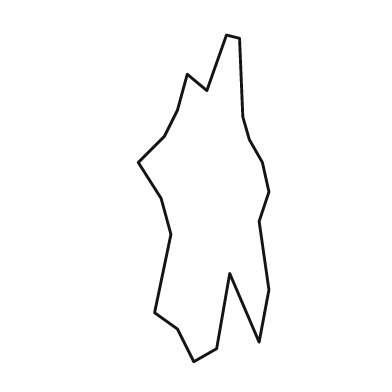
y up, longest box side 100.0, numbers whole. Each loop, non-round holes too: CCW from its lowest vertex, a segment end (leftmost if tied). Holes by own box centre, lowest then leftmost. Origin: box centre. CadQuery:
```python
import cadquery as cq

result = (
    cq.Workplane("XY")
    .moveTo(-3.0, -50.0)
    .lineTo(4.0, -46.0)
    .lineTo(8.0, -23.0)
    .lineTo(17.0, -44.0)
    .lineTo(20.0, -28.0)
    .lineTo(17.0, -7.0)
    .lineTo(20.0, 2.0)
    .lineTo(18.0, 11.0)
    .lineTo(14.0, 18.0)
    .lineTo(12.0, 25.0)
    .lineTo(11.0, 49.0)
    .lineTo(7.0, 50.0)
    .lineTo(1.0, 33.0)
    .lineTo(-5.0, 38.0)
    .lineTo(-8.0, 27.0)
    .lineTo(-12.0, 19.0)
    .lineTo(-20.0, 11.0)
    .lineTo(-13.0, 0.0)
    .lineTo(-10.0, -11.0)
    .lineTo(-15.0, -35.0)
    .lineTo(-8.0, -40.0)
    .close()
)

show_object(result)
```